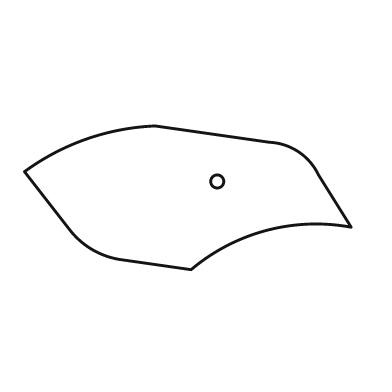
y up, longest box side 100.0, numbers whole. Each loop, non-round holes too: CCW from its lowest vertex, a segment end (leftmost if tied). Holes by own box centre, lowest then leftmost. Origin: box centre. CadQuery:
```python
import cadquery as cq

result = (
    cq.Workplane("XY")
    .moveTo(1.0, -22.0)
    .threePointArc((24.0, -10.0), (50.0, -9.0))
    .lineTo(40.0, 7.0)
    .threePointArc((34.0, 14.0), (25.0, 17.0))
    .lineTo(-10.0, 22.0)
    .threePointArc((-31.0, 18.0), (-50.0, 8.0))
    .lineTo(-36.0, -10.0)
    .threePointArc((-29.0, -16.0), (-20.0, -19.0))
    .close()
    .moveTo(9.0, 5.0)
    .circle(2.0)
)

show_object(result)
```